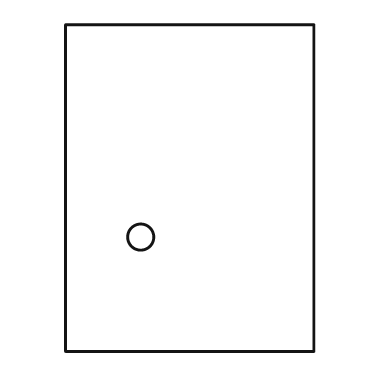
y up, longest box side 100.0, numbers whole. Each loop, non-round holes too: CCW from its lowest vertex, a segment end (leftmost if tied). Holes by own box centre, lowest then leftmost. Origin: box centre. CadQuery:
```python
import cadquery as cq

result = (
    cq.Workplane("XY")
    .moveTo(-38.0, -50.0)
    .lineTo(38.0, -50.0)
    .lineTo(38.0, 50.0)
    .lineTo(-38.0, 50.0)
    .close()
    .moveTo(-15.0, -15.0)
    .circle(4.0)
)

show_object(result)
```